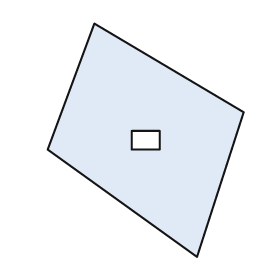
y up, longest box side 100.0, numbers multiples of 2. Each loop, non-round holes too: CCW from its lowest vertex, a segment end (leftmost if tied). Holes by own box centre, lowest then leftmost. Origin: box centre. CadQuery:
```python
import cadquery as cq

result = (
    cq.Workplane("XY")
    .moveTo(22.0, -50.0)
    .lineTo(42.0, 12.0)
    .lineTo(-22.0, 50.0)
    .lineTo(-42.0, -4.0)
    .close()
    .moveTo(-6.0, -4.0)
    .lineTo(6.0, -4.0)
    .lineTo(6.0, 4.0)
    .lineTo(-6.0, 4.0)
    .close()
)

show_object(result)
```